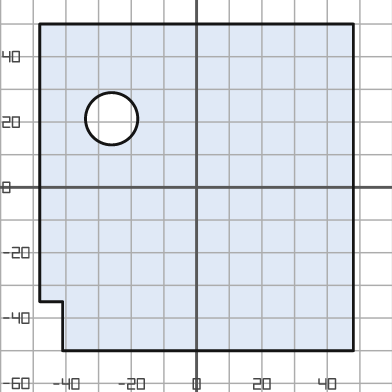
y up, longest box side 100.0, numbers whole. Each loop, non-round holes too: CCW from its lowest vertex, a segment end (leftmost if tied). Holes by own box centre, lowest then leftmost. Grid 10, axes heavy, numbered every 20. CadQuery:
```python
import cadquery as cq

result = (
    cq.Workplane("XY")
    .moveTo(-41.0, -50.0)
    .lineTo(48.0, -50.0)
    .lineTo(48.0, 50.0)
    .lineTo(-48.0, 50.0)
    .lineTo(-48.0, -35.0)
    .lineTo(-41.0, -35.0)
    .close()
    .moveTo(-26.0, 21.0)
    .circle(8.0)
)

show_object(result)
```